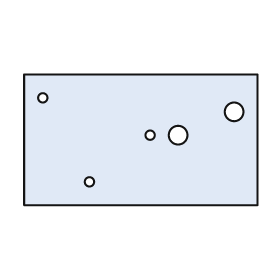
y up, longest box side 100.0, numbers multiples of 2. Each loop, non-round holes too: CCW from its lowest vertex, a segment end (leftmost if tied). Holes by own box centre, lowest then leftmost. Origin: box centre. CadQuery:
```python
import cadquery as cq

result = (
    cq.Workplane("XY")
    .moveTo(-50.0, -28.0)
    .lineTo(50.0, -28.0)
    .lineTo(50.0, 28.0)
    .lineTo(-50.0, 28.0)
    .close()
    .moveTo(-22.0, -18.0)
    .circle(2.0)
    .moveTo(4.0, 2.0)
    .circle(2.0)
    .moveTo(16.0, 2.0)
    .circle(4.0)
    .moveTo(40.0, 12.0)
    .circle(4.0)
    .moveTo(-42.0, 18.0)
    .circle(2.0)
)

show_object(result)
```